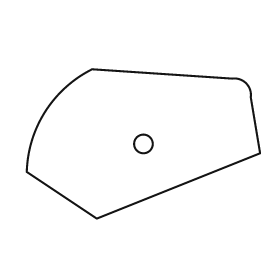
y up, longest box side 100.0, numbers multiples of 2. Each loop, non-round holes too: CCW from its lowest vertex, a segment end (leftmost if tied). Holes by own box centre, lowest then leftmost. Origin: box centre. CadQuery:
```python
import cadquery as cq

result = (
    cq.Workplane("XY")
    .moveTo(-20.0, -32.0)
    .lineTo(50.0, -4.0)
    .lineTo(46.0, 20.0)
    .threePointArc((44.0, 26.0), (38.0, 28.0))
    .lineTo(-22.0, 32.0)
    .threePointArc((-42.0, 14.0), (-50.0, -12.0))
    .close()
    .moveTo(0.0, 0.0)
    .circle(4.0)
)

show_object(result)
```